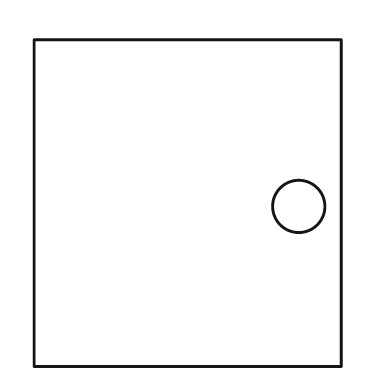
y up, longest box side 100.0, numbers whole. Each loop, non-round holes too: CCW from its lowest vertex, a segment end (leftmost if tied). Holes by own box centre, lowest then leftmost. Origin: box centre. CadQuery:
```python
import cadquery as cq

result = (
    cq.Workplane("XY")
    .moveTo(-47.0, -50.0)
    .lineTo(47.0, -50.0)
    .lineTo(47.0, 50.0)
    .lineTo(-47.0, 50.0)
    .close()
    .moveTo(34.0, -1.0)
    .circle(8.0)
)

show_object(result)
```